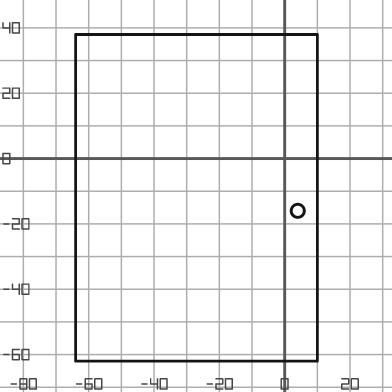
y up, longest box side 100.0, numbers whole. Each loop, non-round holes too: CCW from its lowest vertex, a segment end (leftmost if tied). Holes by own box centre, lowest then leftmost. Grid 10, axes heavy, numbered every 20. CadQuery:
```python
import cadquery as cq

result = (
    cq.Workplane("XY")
    .moveTo(-64.0, -62.0)
    .lineTo(10.0, -62.0)
    .lineTo(10.0, 38.0)
    .lineTo(-64.0, 38.0)
    .close()
    .moveTo(4.0, -16.0)
    .circle(2.0)
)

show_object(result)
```